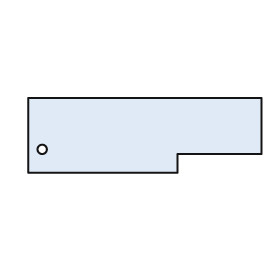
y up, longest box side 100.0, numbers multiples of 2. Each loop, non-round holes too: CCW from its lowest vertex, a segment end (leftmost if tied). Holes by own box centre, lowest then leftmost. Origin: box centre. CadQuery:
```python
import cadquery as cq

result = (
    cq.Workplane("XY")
    .moveTo(-50.0, -16.0)
    .lineTo(14.0, -16.0)
    .lineTo(14.0, -8.0)
    .lineTo(50.0, -8.0)
    .lineTo(50.0, 16.0)
    .lineTo(-50.0, 16.0)
    .close()
    .moveTo(-44.0, -6.0)
    .circle(2.0)
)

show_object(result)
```